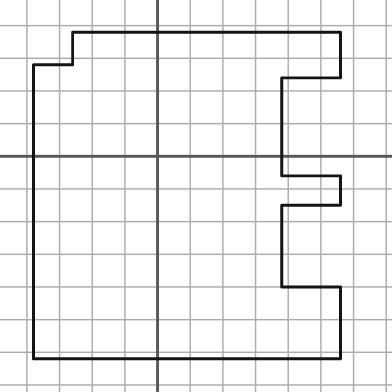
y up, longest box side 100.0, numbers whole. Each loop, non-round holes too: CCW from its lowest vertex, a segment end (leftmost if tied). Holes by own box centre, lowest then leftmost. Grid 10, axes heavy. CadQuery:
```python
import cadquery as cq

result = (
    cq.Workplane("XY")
    .moveTo(-38.0, -62.0)
    .lineTo(56.0, -62.0)
    .lineTo(56.0, -40.0)
    .lineTo(38.0, -40.0)
    .lineTo(38.0, -15.0)
    .lineTo(56.0, -15.0)
    .lineTo(56.0, -6.0)
    .lineTo(38.0, -6.0)
    .lineTo(38.0, 24.0)
    .lineTo(56.0, 24.0)
    .lineTo(56.0, 38.0)
    .lineTo(-26.0, 38.0)
    .lineTo(-26.0, 28.0)
    .lineTo(-38.0, 28.0)
    .close()
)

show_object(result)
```